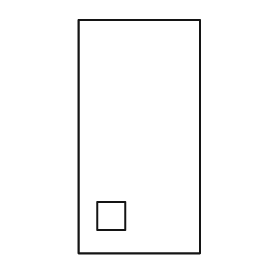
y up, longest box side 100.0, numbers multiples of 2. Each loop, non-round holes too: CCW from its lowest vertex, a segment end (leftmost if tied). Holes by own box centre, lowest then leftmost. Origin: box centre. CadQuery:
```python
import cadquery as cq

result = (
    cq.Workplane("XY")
    .moveTo(-26.0, -50.0)
    .lineTo(26.0, -50.0)
    .lineTo(26.0, 50.0)
    .lineTo(-26.0, 50.0)
    .close()
    .moveTo(-18.0, -40.0)
    .lineTo(-6.0, -40.0)
    .lineTo(-6.0, -28.0)
    .lineTo(-18.0, -28.0)
    .close()
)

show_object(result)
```